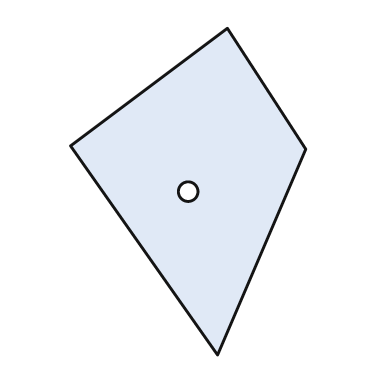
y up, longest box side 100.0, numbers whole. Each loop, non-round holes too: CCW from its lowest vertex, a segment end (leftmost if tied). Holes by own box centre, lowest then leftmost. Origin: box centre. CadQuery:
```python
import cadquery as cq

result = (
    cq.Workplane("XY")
    .moveTo(9.0, -50.0)
    .lineTo(36.0, 13.0)
    .lineTo(12.0, 50.0)
    .lineTo(-36.0, 14.0)
    .close()
    .moveTo(0.0, 0.0)
    .circle(3.0)
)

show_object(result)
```